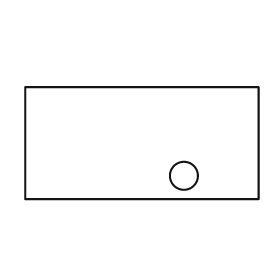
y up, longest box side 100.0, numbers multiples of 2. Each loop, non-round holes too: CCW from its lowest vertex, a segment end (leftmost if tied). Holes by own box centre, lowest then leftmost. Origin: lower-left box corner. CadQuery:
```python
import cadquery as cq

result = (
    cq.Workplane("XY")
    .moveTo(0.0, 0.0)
    .lineTo(100.0, 0.0)
    .lineTo(100.0, 48.0)
    .lineTo(0.0, 48.0)
    .close()
    .moveTo(68.0, 10.0)
    .circle(6.0)
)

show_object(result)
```